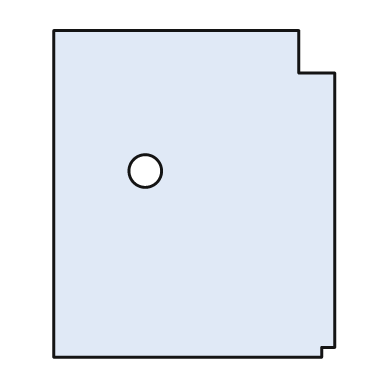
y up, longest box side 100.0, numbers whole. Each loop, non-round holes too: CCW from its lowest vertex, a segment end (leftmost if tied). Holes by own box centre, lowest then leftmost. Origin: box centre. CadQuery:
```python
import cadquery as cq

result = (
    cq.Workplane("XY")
    .moveTo(-43.0, -50.0)
    .lineTo(39.0, -50.0)
    .lineTo(39.0, -47.0)
    .lineTo(43.0, -47.0)
    .lineTo(43.0, 37.0)
    .lineTo(32.0, 37.0)
    .lineTo(32.0, 50.0)
    .lineTo(-43.0, 50.0)
    .close()
    .moveTo(-15.0, 7.0)
    .circle(5.0)
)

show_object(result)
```